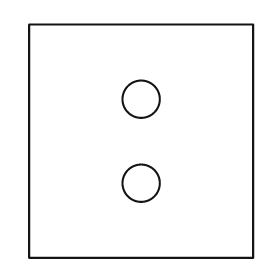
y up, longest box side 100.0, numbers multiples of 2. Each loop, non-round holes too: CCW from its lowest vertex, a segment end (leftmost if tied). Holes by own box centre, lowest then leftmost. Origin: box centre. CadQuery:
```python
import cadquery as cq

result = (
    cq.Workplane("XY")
    .moveTo(-48.0, -50.0)
    .lineTo(48.0, -50.0)
    .lineTo(48.0, 50.0)
    .lineTo(-48.0, 50.0)
    .close()
    .moveTo(0.0, -18.0)
    .circle(8.0)
    .moveTo(0.0, 18.0)
    .circle(8.0)
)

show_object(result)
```